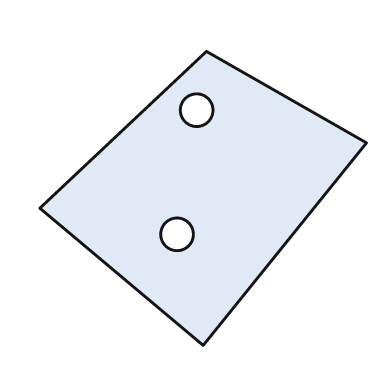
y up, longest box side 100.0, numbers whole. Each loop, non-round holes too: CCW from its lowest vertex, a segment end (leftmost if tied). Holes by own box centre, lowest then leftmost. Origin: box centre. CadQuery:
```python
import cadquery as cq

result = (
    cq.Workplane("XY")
    .moveTo(0.0, -45.0)
    .lineTo(50.0, 17.0)
    .lineTo(1.0, 45.0)
    .lineTo(-50.0, -3.0)
    .close()
    .moveTo(-8.0, -11.0)
    .circle(5.0)
    .moveTo(-2.0, 27.0)
    .circle(5.0)
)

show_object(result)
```